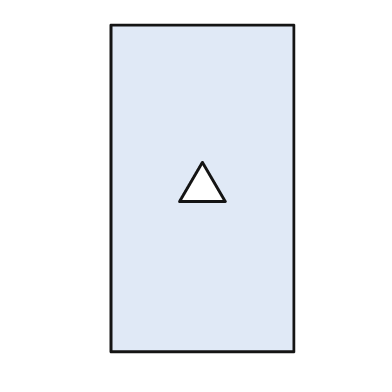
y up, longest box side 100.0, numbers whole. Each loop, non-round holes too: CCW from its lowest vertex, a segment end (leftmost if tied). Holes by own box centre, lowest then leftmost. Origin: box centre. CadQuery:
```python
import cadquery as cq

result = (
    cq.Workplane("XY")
    .moveTo(-28.0, -50.0)
    .lineTo(28.0, -50.0)
    .lineTo(28.0, 50.0)
    .lineTo(-28.0, 50.0)
    .close()
    .moveTo(-7.0, -4.0)
    .lineTo(7.0, -4.0)
    .lineTo(0.0, 8.0)
    .close()
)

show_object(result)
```